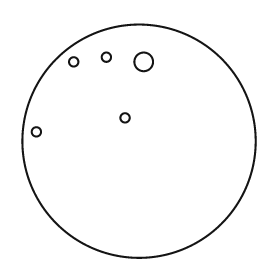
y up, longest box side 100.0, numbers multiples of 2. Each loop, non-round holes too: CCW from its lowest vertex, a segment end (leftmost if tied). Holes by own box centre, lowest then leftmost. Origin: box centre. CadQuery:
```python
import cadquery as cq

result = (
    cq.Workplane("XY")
    .moveTo(0.0, 0.0)
    .circle(50.0)
    .moveTo(-44.0, 4.0)
    .circle(2.0)
    .moveTo(-6.0, 10.0)
    .circle(2.0)
    .moveTo(-28.0, 34.0)
    .circle(2.0)
    .moveTo(2.0, 34.0)
    .circle(4.0)
    .moveTo(-14.0, 36.0)
    .circle(2.0)
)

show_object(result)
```